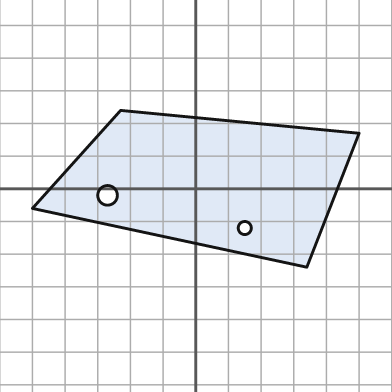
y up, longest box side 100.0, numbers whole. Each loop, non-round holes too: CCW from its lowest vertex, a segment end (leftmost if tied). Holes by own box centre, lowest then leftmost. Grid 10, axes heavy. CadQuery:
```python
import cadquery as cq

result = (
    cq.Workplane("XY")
    .moveTo(34.0, -24.0)
    .lineTo(50.0, 17.0)
    .lineTo(-23.0, 24.0)
    .lineTo(-50.0, -6.0)
    .close()
    .moveTo(15.0, -12.0)
    .circle(2.0)
    .moveTo(-27.0, -2.0)
    .circle(3.0)
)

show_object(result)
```